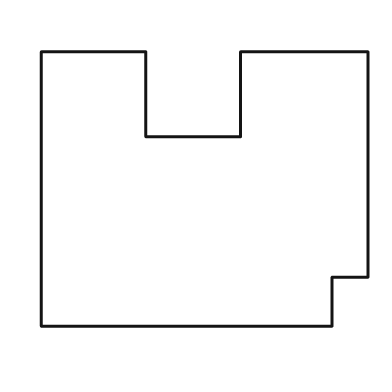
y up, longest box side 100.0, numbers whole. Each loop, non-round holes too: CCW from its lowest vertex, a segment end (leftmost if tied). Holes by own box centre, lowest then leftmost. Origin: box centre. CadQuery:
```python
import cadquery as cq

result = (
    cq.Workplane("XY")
    .moveTo(-50.0, -42.0)
    .lineTo(39.0, -42.0)
    .lineTo(39.0, -27.0)
    .lineTo(50.0, -27.0)
    .lineTo(50.0, 42.0)
    .lineTo(11.0, 42.0)
    .lineTo(11.0, 16.0)
    .lineTo(-18.0, 16.0)
    .lineTo(-18.0, 42.0)
    .lineTo(-50.0, 42.0)
    .close()
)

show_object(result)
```